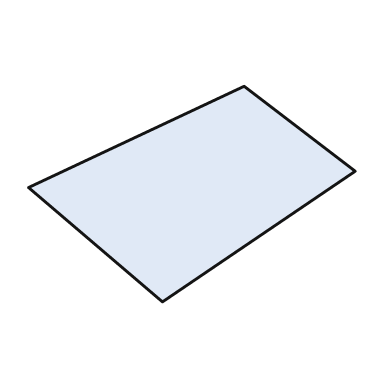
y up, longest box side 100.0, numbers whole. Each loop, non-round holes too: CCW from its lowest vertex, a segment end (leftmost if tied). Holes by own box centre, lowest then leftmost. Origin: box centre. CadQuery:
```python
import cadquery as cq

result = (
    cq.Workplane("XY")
    .moveTo(-9.0, -33.0)
    .lineTo(50.0, 7.0)
    .lineTo(16.0, 33.0)
    .lineTo(-50.0, 2.0)
    .close()
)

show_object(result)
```